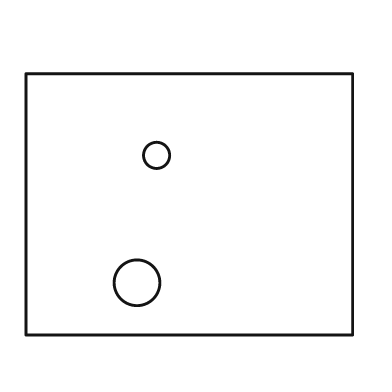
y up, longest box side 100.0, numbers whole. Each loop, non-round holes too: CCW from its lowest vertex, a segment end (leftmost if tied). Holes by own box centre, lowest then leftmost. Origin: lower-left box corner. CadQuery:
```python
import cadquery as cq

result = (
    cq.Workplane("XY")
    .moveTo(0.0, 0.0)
    .lineTo(100.0, 0.0)
    .lineTo(100.0, 80.0)
    .lineTo(0.0, 80.0)
    .close()
    .moveTo(34.0, 16.0)
    .circle(7.0)
    .moveTo(40.0, 55.0)
    .circle(4.0)
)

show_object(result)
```